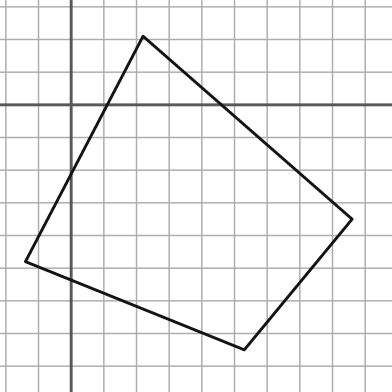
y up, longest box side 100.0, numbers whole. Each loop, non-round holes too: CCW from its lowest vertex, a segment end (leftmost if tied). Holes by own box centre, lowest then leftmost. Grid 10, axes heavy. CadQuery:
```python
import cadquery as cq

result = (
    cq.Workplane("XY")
    .moveTo(53.0, -75.0)
    .lineTo(86.0, -35.0)
    .lineTo(22.0, 21.0)
    .lineTo(-14.0, -48.0)
    .close()
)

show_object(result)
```